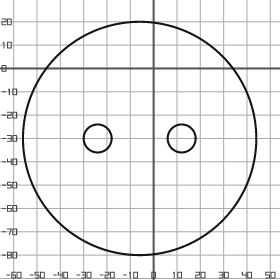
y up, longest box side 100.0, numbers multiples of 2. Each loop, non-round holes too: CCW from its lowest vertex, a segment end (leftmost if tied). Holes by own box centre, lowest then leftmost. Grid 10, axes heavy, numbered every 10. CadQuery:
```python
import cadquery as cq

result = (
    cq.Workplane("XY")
    .moveTo(-6.0, -30.0)
    .circle(50.0)
    .moveTo(-24.0, -30.0)
    .circle(6.0)
    .moveTo(12.0, -30.0)
    .circle(6.0)
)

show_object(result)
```